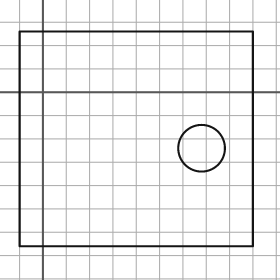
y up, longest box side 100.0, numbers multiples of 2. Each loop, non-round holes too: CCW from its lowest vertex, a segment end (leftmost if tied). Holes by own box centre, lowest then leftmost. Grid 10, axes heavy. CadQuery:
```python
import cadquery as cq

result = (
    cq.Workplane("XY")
    .moveTo(-10.0, -66.0)
    .lineTo(90.0, -66.0)
    .lineTo(90.0, 26.0)
    .lineTo(-10.0, 26.0)
    .close()
    .moveTo(68.0, -24.0)
    .circle(10.0)
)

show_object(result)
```